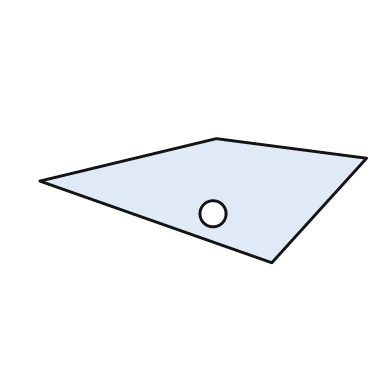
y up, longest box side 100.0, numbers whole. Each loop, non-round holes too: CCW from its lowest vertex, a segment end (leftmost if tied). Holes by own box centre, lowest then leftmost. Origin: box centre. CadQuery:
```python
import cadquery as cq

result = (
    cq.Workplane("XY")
    .moveTo(21.0, -19.0)
    .lineTo(50.0, 13.0)
    .lineTo(4.0, 19.0)
    .lineTo(-50.0, 6.0)
    .close()
    .moveTo(3.0, -4.0)
    .circle(4.0)
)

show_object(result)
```